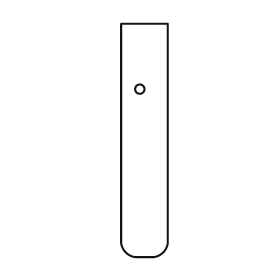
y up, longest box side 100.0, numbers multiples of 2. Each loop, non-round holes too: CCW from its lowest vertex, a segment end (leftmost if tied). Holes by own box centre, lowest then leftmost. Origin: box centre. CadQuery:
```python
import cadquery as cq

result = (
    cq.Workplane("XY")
    .moveTo(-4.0, -50.0)
    .lineTo(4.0, -50.0)
    .threePointArc((8.0, -48.0), (10.0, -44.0))
    .lineTo(10.0, 50.0)
    .lineTo(-10.0, 50.0)
    .lineTo(-10.0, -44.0)
    .threePointArc((-8.0, -48.0), (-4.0, -50.0))
    .close()
    .moveTo(-2.0, 22.0)
    .circle(2.0)
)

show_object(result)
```